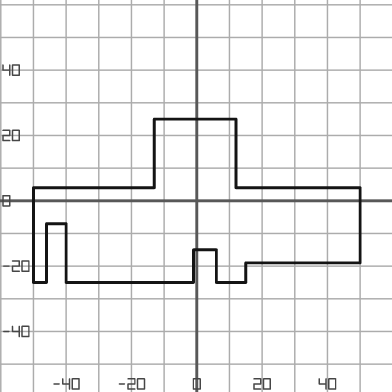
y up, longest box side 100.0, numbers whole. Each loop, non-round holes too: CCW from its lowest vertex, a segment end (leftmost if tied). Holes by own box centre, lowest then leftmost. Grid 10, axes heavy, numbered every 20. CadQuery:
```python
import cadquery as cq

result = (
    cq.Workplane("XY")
    .moveTo(-50.0, -25.0)
    .lineTo(-46.0, -25.0)
    .lineTo(-46.0, -7.0)
    .lineTo(-40.0, -7.0)
    .lineTo(-40.0, -25.0)
    .lineTo(-1.0, -25.0)
    .lineTo(-1.0, -15.0)
    .lineTo(6.0, -15.0)
    .lineTo(6.0, -25.0)
    .lineTo(15.0, -25.0)
    .lineTo(15.0, -19.0)
    .lineTo(50.0, -19.0)
    .lineTo(50.0, 4.0)
    .lineTo(12.0, 4.0)
    .lineTo(12.0, 25.0)
    .lineTo(-13.0, 25.0)
    .lineTo(-13.0, 4.0)
    .lineTo(-50.0, 4.0)
    .close()
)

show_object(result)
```